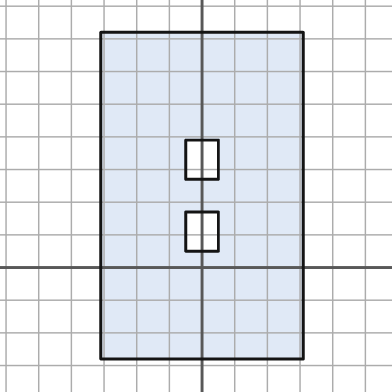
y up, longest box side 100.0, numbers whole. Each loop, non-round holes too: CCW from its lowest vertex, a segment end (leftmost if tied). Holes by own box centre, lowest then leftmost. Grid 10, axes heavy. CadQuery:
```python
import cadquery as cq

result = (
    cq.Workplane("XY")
    .moveTo(-31.0, -28.0)
    .lineTo(31.0, -28.0)
    .lineTo(31.0, 72.0)
    .lineTo(-31.0, 72.0)
    .close()
    .moveTo(-5.0, 5.0)
    .lineTo(5.0, 5.0)
    .lineTo(5.0, 17.0)
    .lineTo(-5.0, 17.0)
    .close()
    .moveTo(-5.0, 27.0)
    .lineTo(5.0, 27.0)
    .lineTo(5.0, 39.0)
    .lineTo(-5.0, 39.0)
    .close()
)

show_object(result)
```